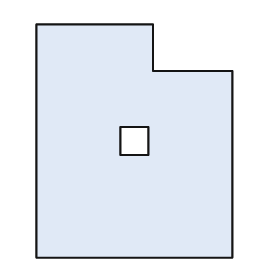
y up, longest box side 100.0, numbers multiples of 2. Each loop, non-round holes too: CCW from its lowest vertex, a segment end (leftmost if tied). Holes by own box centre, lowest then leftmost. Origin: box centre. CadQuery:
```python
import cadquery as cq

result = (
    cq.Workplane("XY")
    .moveTo(-42.0, -50.0)
    .lineTo(42.0, -50.0)
    .lineTo(42.0, 30.0)
    .lineTo(8.0, 30.0)
    .lineTo(8.0, 50.0)
    .lineTo(-42.0, 50.0)
    .close()
    .moveTo(-6.0, -6.0)
    .lineTo(6.0, -6.0)
    .lineTo(6.0, 6.0)
    .lineTo(-6.0, 6.0)
    .close()
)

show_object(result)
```